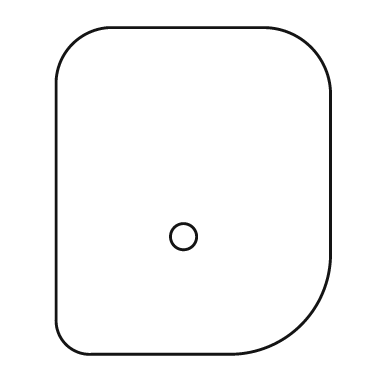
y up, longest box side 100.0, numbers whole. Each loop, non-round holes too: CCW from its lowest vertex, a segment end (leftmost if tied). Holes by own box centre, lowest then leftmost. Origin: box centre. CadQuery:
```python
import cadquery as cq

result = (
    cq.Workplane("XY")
    .moveTo(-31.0, -50.0)
    .lineTo(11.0, -50.0)
    .threePointArc((33.0, -41.0), (42.0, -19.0))
    .lineTo(42.0, 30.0)
    .threePointArc((36.0, 44.0), (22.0, 50.0))
    .lineTo(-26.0, 50.0)
    .threePointArc((-37.0, 45.0), (-42.0, 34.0))
    .lineTo(-42.0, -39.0)
    .threePointArc((-39.0, -47.0), (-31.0, -50.0))
    .close()
    .moveTo(-3.0, -14.0)
    .circle(4.0)
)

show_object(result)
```